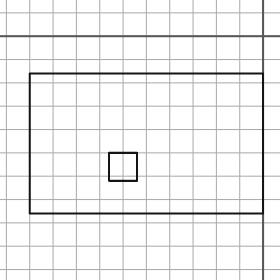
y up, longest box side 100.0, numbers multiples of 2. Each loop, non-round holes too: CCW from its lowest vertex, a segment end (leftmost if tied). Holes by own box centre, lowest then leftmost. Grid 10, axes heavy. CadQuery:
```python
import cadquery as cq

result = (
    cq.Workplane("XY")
    .moveTo(-100.0, -76.0)
    .lineTo(0.0, -76.0)
    .lineTo(0.0, -16.0)
    .lineTo(-100.0, -16.0)
    .close()
    .moveTo(-66.0, -62.0)
    .lineTo(-54.0, -62.0)
    .lineTo(-54.0, -50.0)
    .lineTo(-66.0, -50.0)
    .close()
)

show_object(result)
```